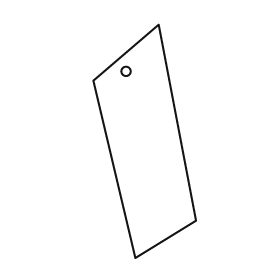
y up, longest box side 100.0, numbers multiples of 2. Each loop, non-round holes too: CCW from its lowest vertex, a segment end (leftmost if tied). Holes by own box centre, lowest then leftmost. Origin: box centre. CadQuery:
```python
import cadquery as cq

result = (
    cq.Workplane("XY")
    .moveTo(-4.0, -50.0)
    .lineTo(22.0, -34.0)
    .lineTo(6.0, 50.0)
    .lineTo(-22.0, 26.0)
    .close()
    .moveTo(-8.0, 30.0)
    .circle(2.0)
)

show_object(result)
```